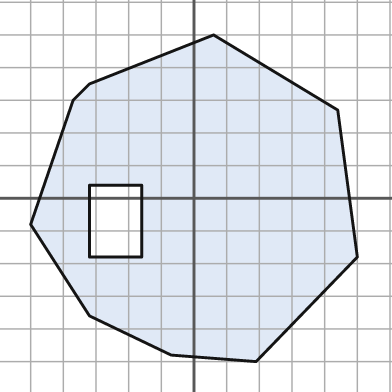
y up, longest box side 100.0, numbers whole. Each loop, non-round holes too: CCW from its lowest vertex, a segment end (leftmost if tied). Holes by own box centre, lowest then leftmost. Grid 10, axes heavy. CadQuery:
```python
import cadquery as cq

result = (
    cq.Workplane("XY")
    .moveTo(19.0, -50.0)
    .lineTo(50.0, -18.0)
    .lineTo(44.0, 27.0)
    .lineTo(6.0, 50.0)
    .lineTo(-32.0, 35.0)
    .lineTo(-37.0, 30.0)
    .lineTo(-50.0, -8.0)
    .lineTo(-32.0, -36.0)
    .lineTo(-7.0, -48.0)
    .close()
    .moveTo(-32.0, -18.0)
    .lineTo(-16.0, -18.0)
    .lineTo(-16.0, 4.0)
    .lineTo(-32.0, 4.0)
    .close()
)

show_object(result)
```